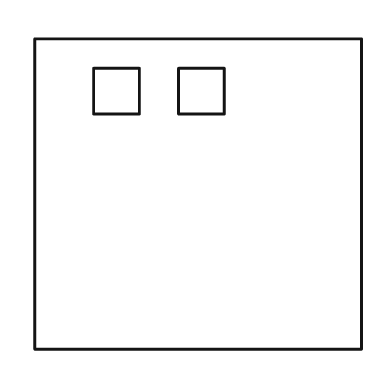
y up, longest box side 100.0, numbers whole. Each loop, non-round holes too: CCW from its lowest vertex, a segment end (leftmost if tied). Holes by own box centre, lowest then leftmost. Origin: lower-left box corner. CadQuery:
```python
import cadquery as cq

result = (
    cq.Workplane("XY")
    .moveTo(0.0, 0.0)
    .lineTo(100.0, 0.0)
    .lineTo(100.0, 95.0)
    .lineTo(0.0, 95.0)
    .close()
    .moveTo(18.0, 72.0)
    .lineTo(32.0, 72.0)
    .lineTo(32.0, 86.0)
    .lineTo(18.0, 86.0)
    .close()
    .moveTo(44.0, 72.0)
    .lineTo(58.0, 72.0)
    .lineTo(58.0, 86.0)
    .lineTo(44.0, 86.0)
    .close()
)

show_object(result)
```